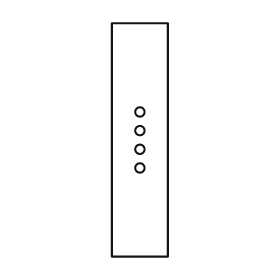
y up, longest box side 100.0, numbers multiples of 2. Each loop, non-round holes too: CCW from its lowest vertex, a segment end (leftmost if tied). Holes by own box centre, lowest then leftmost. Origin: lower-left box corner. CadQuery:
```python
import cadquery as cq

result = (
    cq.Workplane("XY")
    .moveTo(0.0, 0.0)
    .lineTo(24.0, 0.0)
    .lineTo(24.0, 100.0)
    .lineTo(0.0, 100.0)
    .close()
    .moveTo(12.0, 38.0)
    .circle(2.0)
    .moveTo(12.0, 46.0)
    .circle(2.0)
    .moveTo(12.0, 54.0)
    .circle(2.0)
    .moveTo(12.0, 62.0)
    .circle(2.0)
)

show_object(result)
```